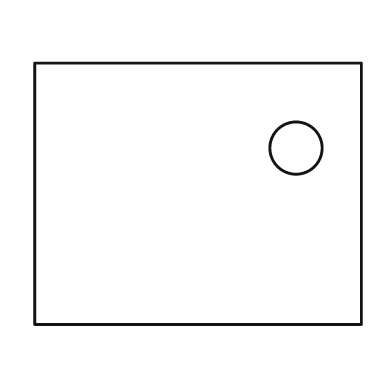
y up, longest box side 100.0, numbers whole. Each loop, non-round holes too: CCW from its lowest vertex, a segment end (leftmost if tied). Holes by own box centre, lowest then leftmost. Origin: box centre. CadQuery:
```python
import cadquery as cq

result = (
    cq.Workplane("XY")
    .moveTo(-50.0, -40.0)
    .lineTo(50.0, -40.0)
    .lineTo(50.0, 40.0)
    .lineTo(-50.0, 40.0)
    .close()
    .moveTo(30.0, 14.0)
    .circle(8.0)
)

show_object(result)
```